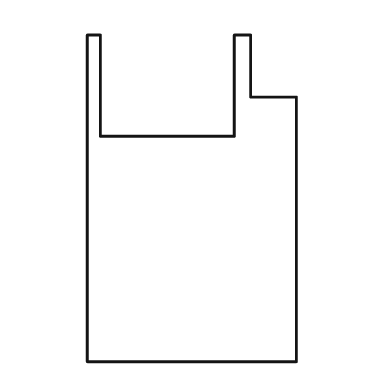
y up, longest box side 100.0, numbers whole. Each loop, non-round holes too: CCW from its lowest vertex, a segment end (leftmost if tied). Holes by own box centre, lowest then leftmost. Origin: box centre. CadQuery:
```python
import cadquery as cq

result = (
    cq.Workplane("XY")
    .moveTo(-32.0, -50.0)
    .lineTo(32.0, -50.0)
    .lineTo(32.0, 31.0)
    .lineTo(18.0, 31.0)
    .lineTo(18.0, 50.0)
    .lineTo(13.0, 50.0)
    .lineTo(13.0, 19.0)
    .lineTo(-28.0, 19.0)
    .lineTo(-28.0, 50.0)
    .lineTo(-32.0, 50.0)
    .close()
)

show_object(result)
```